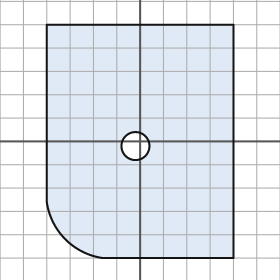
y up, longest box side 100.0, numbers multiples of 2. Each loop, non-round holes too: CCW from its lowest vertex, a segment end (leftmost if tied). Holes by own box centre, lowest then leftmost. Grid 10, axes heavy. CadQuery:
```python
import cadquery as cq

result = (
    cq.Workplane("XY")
    .moveTo(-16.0, -50.0)
    .lineTo(40.0, -50.0)
    .lineTo(40.0, 50.0)
    .lineTo(-40.0, 50.0)
    .lineTo(-40.0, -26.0)
    .threePointArc((-32.0, -42.0), (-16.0, -50.0))
    .close()
    .moveTo(-2.0, -2.0)
    .circle(6.0)
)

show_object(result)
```